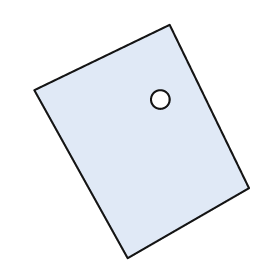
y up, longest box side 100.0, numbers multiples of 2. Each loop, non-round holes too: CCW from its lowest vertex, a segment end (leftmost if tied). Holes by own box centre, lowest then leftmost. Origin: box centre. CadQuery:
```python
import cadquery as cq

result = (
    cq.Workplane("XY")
    .moveTo(-6.0, -50.0)
    .lineTo(46.0, -20.0)
    .lineTo(12.0, 50.0)
    .lineTo(-46.0, 22.0)
    .close()
    .moveTo(8.0, 18.0)
    .circle(4.0)
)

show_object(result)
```